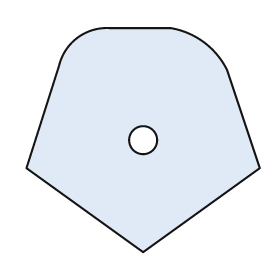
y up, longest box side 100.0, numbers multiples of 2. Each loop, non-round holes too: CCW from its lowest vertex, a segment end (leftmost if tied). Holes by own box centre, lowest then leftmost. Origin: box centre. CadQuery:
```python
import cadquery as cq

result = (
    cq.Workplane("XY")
    .moveTo(0.0, -48.0)
    .lineTo(50.0, -12.0)
    .lineTo(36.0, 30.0)
    .threePointArc((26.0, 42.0), (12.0, 48.0))
    .lineTo(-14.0, 48.0)
    .threePointArc((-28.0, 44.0), (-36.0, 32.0))
    .lineTo(-50.0, -12.0)
    .close()
    .moveTo(0.0, 0.0)
    .circle(6.0)
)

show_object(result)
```